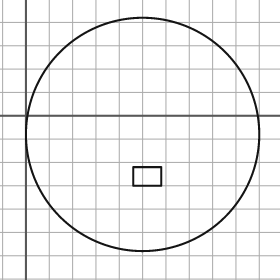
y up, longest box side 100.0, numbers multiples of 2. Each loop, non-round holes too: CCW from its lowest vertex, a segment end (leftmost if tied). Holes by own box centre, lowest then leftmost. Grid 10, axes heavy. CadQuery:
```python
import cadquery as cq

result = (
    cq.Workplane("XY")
    .moveTo(50.0, -8.0)
    .circle(50.0)
    .moveTo(46.0, -30.0)
    .lineTo(58.0, -30.0)
    .lineTo(58.0, -22.0)
    .lineTo(46.0, -22.0)
    .close()
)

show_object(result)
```